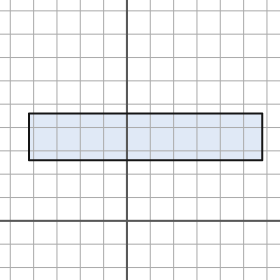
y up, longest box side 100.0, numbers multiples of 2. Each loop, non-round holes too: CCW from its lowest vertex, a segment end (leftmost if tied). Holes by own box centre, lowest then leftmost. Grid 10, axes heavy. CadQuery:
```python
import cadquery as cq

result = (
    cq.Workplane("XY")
    .moveTo(-42.0, 26.0)
    .lineTo(58.0, 26.0)
    .lineTo(58.0, 46.0)
    .lineTo(-42.0, 46.0)
    .close()
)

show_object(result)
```